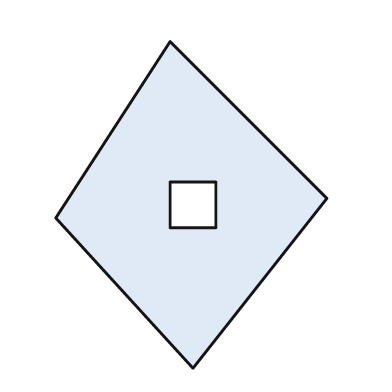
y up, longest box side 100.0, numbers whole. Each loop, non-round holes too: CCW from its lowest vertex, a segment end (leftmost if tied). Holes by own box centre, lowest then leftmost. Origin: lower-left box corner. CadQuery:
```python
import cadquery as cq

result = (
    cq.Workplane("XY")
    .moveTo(42.0, 0.0)
    .lineTo(83.0, 52.0)
    .lineTo(35.0, 100.0)
    .lineTo(0.0, 46.0)
    .close()
    .moveTo(35.0, 43.0)
    .lineTo(49.0, 43.0)
    .lineTo(49.0, 57.0)
    .lineTo(35.0, 57.0)
    .close()
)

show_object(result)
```